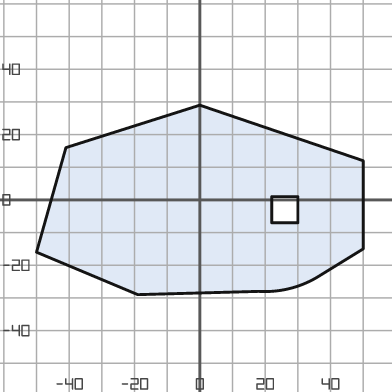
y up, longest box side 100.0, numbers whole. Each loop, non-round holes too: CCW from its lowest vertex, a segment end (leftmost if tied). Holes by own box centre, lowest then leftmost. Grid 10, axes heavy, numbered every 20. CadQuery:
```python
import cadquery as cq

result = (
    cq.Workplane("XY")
    .moveTo(-19.0, -29.0)
    .lineTo(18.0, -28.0)
    .threePointArc((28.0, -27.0), (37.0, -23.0))
    .lineTo(50.0, -15.0)
    .lineTo(50.0, 12.0)
    .lineTo(0.0, 29.0)
    .lineTo(-41.0, 16.0)
    .lineTo(-50.0, -16.0)
    .close()
    .moveTo(22.0, -7.0)
    .lineTo(30.0, -7.0)
    .lineTo(30.0, 1.0)
    .lineTo(22.0, 1.0)
    .close()
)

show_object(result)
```